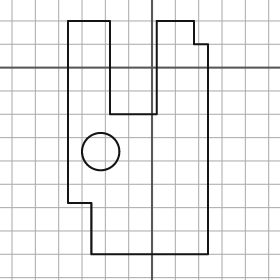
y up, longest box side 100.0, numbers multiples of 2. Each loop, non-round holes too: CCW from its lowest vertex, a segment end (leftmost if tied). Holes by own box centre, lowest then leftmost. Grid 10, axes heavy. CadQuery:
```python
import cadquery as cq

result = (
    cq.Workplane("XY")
    .moveTo(-26.0, -80.0)
    .lineTo(24.0, -80.0)
    .lineTo(24.0, 10.0)
    .lineTo(18.0, 10.0)
    .lineTo(18.0, 20.0)
    .lineTo(2.0, 20.0)
    .lineTo(2.0, -20.0)
    .lineTo(-18.0, -20.0)
    .lineTo(-18.0, 20.0)
    .lineTo(-36.0, 20.0)
    .lineTo(-36.0, -58.0)
    .lineTo(-26.0, -58.0)
    .close()
    .moveTo(-22.0, -36.0)
    .circle(8.0)
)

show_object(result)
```